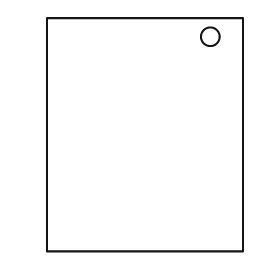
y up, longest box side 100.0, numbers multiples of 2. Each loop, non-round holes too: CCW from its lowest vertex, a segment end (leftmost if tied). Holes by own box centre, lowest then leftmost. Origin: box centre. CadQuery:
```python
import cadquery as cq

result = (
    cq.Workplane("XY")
    .moveTo(-42.0, -50.0)
    .lineTo(42.0, -50.0)
    .lineTo(42.0, 50.0)
    .lineTo(-42.0, 50.0)
    .close()
    .moveTo(28.0, 42.0)
    .circle(4.0)
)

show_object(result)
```